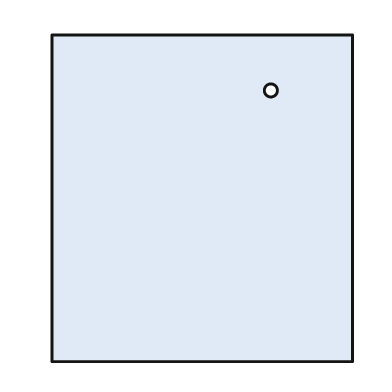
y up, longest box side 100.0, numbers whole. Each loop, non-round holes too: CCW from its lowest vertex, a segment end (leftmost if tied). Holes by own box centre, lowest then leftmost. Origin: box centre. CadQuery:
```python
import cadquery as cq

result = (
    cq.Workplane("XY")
    .moveTo(-46.0, -50.0)
    .lineTo(46.0, -50.0)
    .lineTo(46.0, 50.0)
    .lineTo(-46.0, 50.0)
    .close()
    .moveTo(21.0, 33.0)
    .circle(2.0)
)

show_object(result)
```